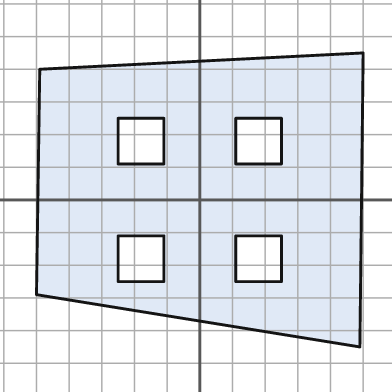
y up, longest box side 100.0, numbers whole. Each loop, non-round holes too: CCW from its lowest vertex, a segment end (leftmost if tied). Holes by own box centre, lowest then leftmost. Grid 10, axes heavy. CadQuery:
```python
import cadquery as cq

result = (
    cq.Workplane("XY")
    .moveTo(49.0, -45.0)
    .lineTo(50.0, 45.0)
    .lineTo(-49.0, 40.0)
    .lineTo(-50.0, -29.0)
    .close()
    .moveTo(-25.0, -25.0)
    .lineTo(-11.0, -25.0)
    .lineTo(-11.0, -11.0)
    .lineTo(-25.0, -11.0)
    .close()
    .moveTo(11.0, -25.0)
    .lineTo(25.0, -25.0)
    .lineTo(25.0, -11.0)
    .lineTo(11.0, -11.0)
    .close()
    .moveTo(-25.0, 11.0)
    .lineTo(-11.0, 11.0)
    .lineTo(-11.0, 25.0)
    .lineTo(-25.0, 25.0)
    .close()
    .moveTo(11.0, 11.0)
    .lineTo(25.0, 11.0)
    .lineTo(25.0, 25.0)
    .lineTo(11.0, 25.0)
    .close()
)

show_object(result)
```